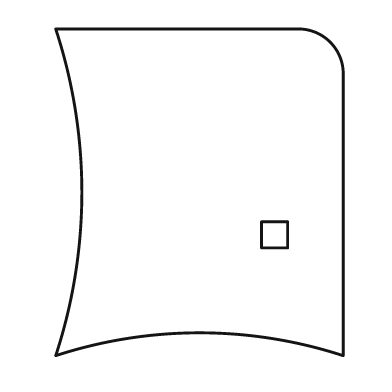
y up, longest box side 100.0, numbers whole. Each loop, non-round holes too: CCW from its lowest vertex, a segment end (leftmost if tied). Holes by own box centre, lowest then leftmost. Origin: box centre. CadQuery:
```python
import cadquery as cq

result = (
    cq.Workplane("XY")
    .moveTo(-44.0, -50.0)
    .threePointArc((0.0, -43.0), (44.0, -50.0))
    .lineTo(44.0, 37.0)
    .threePointArc((40.0, 46.0), (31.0, 50.0))
    .lineTo(-44.0, 50.0)
    .threePointArc((-36.0, 0.0), (-44.0, -50.0))
    .close()
    .moveTo(19.0, -17.0)
    .lineTo(27.0, -17.0)
    .lineTo(27.0, -9.0)
    .lineTo(19.0, -9.0)
    .close()
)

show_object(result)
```